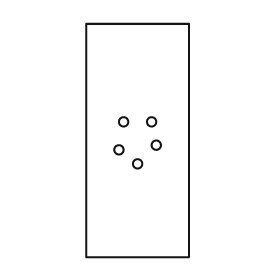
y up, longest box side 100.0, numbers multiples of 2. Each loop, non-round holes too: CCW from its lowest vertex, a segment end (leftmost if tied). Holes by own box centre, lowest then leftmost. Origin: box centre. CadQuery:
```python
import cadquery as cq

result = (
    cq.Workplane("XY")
    .moveTo(-22.0, -50.0)
    .lineTo(22.0, -50.0)
    .lineTo(22.0, 50.0)
    .lineTo(-22.0, 50.0)
    .close()
    .moveTo(0.0, -10.0)
    .circle(2.0)
    .moveTo(-8.0, -4.0)
    .circle(2.0)
    .moveTo(8.0, -2.0)
    .circle(2.0)
    .moveTo(-6.0, 8.0)
    .circle(2.0)
    .moveTo(6.0, 8.0)
    .circle(2.0)
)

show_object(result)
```